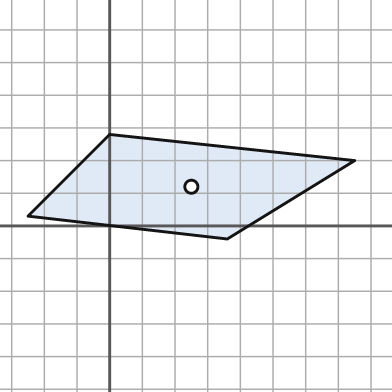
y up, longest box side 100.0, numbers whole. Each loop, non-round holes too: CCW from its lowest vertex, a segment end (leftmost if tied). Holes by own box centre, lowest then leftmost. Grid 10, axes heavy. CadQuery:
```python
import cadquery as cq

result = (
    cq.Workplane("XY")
    .moveTo(36.0, -4.0)
    .lineTo(75.0, 20.0)
    .lineTo(0.0, 28.0)
    .lineTo(-25.0, 3.0)
    .close()
    .moveTo(25.0, 12.0)
    .circle(2.0)
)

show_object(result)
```